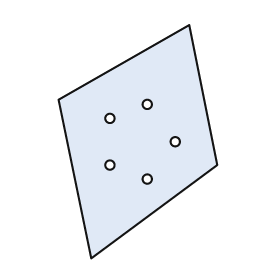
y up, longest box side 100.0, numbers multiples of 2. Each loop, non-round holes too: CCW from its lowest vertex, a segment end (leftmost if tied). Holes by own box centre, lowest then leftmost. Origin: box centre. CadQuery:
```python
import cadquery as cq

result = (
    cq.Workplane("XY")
    .moveTo(-20.0, -50.0)
    .lineTo(34.0, -10.0)
    .lineTo(22.0, 50.0)
    .lineTo(-34.0, 18.0)
    .close()
    .moveTo(4.0, -16.0)
    .circle(2.0)
    .moveTo(-12.0, -10.0)
    .circle(2.0)
    .moveTo(16.0, 0.0)
    .circle(2.0)
    .moveTo(-12.0, 10.0)
    .circle(2.0)
    .moveTo(4.0, 16.0)
    .circle(2.0)
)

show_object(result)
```